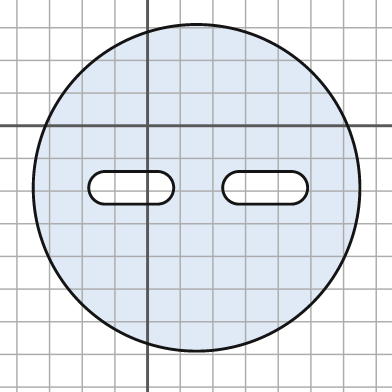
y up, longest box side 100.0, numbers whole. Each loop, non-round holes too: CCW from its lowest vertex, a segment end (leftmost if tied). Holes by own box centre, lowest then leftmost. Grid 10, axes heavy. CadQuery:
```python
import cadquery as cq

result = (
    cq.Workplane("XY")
    .moveTo(15.0, -19.0)
    .circle(50.0)
    .moveTo(-13.0, -24.0)
    .lineTo(3.0, -24.0)
    .threePointArc((8.0, -19.0), (3.0, -14.0))
    .lineTo(-13.0, -14.0)
    .threePointArc((-18.0, -19.0), (-13.0, -24.0))
    .close()
    .moveTo(28.0, -24.0)
    .lineTo(44.0, -24.0)
    .threePointArc((49.0, -19.0), (44.0, -14.0))
    .lineTo(28.0, -14.0)
    .threePointArc((23.0, -19.0), (28.0, -24.0))
    .close()
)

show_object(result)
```